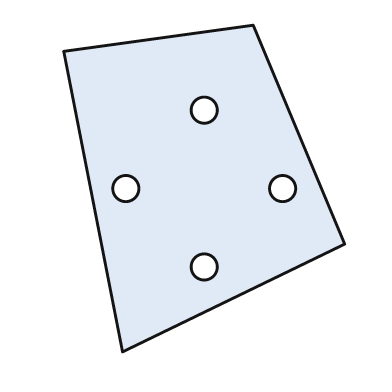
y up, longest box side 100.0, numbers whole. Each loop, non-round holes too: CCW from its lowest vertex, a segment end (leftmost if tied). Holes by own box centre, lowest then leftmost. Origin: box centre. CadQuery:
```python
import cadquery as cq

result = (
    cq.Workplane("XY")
    .moveTo(-25.0, -50.0)
    .lineTo(43.0, -17.0)
    .lineTo(15.0, 50.0)
    .lineTo(-43.0, 42.0)
    .close()
    .moveTo(0.0, -24.0)
    .circle(4.0)
    .moveTo(-24.0, 0.0)
    .circle(4.0)
    .moveTo(24.0, 0.0)
    .circle(4.0)
    .moveTo(0.0, 24.0)
    .circle(4.0)
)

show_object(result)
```